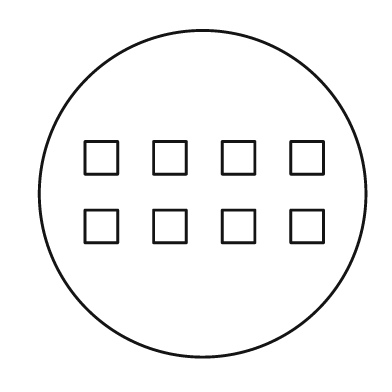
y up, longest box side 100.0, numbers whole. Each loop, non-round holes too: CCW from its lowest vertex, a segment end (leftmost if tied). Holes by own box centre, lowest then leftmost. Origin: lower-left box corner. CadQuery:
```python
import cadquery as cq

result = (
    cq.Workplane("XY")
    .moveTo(50.0, 50.0)
    .circle(50.0)
    .moveTo(14.0, 35.0)
    .lineTo(24.0, 35.0)
    .lineTo(24.0, 45.0)
    .lineTo(14.0, 45.0)
    .close()
    .moveTo(35.0, 35.0)
    .lineTo(45.0, 35.0)
    .lineTo(45.0, 45.0)
    .lineTo(35.0, 45.0)
    .close()
    .moveTo(56.0, 35.0)
    .lineTo(66.0, 35.0)
    .lineTo(66.0, 45.0)
    .lineTo(56.0, 45.0)
    .close()
    .moveTo(77.0, 35.0)
    .lineTo(87.0, 35.0)
    .lineTo(87.0, 45.0)
    .lineTo(77.0, 45.0)
    .close()
    .moveTo(14.0, 56.0)
    .lineTo(24.0, 56.0)
    .lineTo(24.0, 66.0)
    .lineTo(14.0, 66.0)
    .close()
    .moveTo(35.0, 56.0)
    .lineTo(45.0, 56.0)
    .lineTo(45.0, 66.0)
    .lineTo(35.0, 66.0)
    .close()
    .moveTo(56.0, 56.0)
    .lineTo(66.0, 56.0)
    .lineTo(66.0, 66.0)
    .lineTo(56.0, 66.0)
    .close()
    .moveTo(77.0, 56.0)
    .lineTo(87.0, 56.0)
    .lineTo(87.0, 66.0)
    .lineTo(77.0, 66.0)
    .close()
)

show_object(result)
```